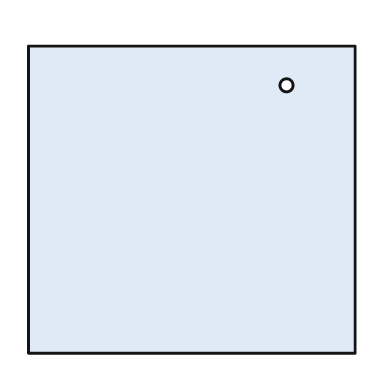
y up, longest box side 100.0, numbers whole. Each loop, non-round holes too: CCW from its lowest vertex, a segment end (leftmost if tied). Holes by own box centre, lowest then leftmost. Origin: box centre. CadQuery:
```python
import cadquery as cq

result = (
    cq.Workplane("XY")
    .moveTo(-50.0, -47.0)
    .lineTo(50.0, -47.0)
    .lineTo(50.0, 47.0)
    .lineTo(-50.0, 47.0)
    .close()
    .moveTo(29.0, 35.0)
    .circle(2.0)
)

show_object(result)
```